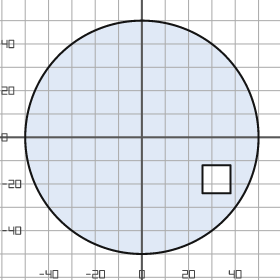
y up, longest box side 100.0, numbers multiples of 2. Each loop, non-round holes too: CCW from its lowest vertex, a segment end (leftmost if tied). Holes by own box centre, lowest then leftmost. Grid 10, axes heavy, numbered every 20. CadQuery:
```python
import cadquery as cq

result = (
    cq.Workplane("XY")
    .moveTo(0.0, 0.0)
    .circle(50.0)
    .moveTo(26.0, -24.0)
    .lineTo(38.0, -24.0)
    .lineTo(38.0, -12.0)
    .lineTo(26.0, -12.0)
    .close()
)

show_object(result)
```